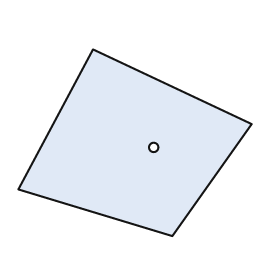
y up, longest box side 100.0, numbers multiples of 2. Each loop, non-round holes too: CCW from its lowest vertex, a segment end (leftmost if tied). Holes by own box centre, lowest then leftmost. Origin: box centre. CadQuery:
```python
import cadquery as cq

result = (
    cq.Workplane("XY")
    .moveTo(16.0, -40.0)
    .lineTo(50.0, 8.0)
    .lineTo(-18.0, 40.0)
    .lineTo(-50.0, -20.0)
    .close()
    .moveTo(8.0, -2.0)
    .circle(2.0)
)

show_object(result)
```